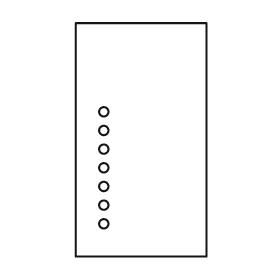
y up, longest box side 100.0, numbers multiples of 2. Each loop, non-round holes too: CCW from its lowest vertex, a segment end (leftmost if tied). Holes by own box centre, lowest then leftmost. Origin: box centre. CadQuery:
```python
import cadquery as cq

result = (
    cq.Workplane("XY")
    .moveTo(-28.0, -50.0)
    .lineTo(28.0, -50.0)
    .lineTo(28.0, 50.0)
    .lineTo(-28.0, 50.0)
    .close()
    .moveTo(-16.0, -36.0)
    .circle(2.0)
    .moveTo(-16.0, -28.0)
    .circle(2.0)
    .moveTo(-16.0, -20.0)
    .circle(2.0)
    .moveTo(-16.0, -12.0)
    .circle(2.0)
    .moveTo(-16.0, -4.0)
    .circle(2.0)
    .moveTo(-16.0, 4.0)
    .circle(2.0)
    .moveTo(-16.0, 12.0)
    .circle(2.0)
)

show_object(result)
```